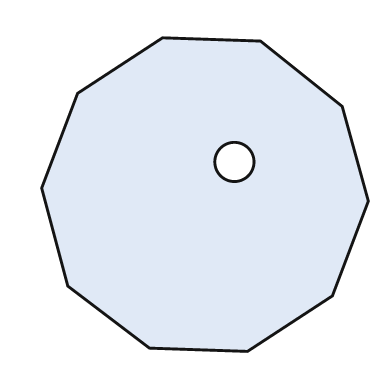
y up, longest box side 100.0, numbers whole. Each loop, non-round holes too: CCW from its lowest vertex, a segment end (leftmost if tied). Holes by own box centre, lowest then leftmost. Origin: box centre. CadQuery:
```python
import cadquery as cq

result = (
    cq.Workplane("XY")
    .moveTo(13.0, -48.0)
    .lineTo(39.0, -31.0)
    .lineTo(50.0, -2.0)
    .lineTo(42.0, 27.0)
    .lineTo(17.0, 47.0)
    .lineTo(-13.0, 48.0)
    .lineTo(-39.0, 31.0)
    .lineTo(-50.0, 2.0)
    .lineTo(-42.0, -28.0)
    .lineTo(-17.0, -47.0)
    .close()
    .moveTo(9.0, 10.0)
    .circle(6.0)
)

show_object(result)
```